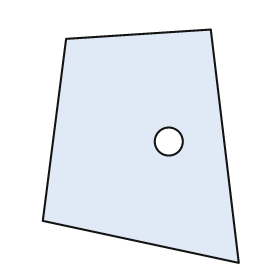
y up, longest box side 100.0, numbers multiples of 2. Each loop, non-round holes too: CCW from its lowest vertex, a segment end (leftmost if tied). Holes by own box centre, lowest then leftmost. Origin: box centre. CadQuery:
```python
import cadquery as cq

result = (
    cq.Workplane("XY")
    .moveTo(42.0, -50.0)
    .lineTo(30.0, 50.0)
    .lineTo(-32.0, 46.0)
    .lineTo(-42.0, -32.0)
    .close()
    .moveTo(12.0, 2.0)
    .circle(6.0)
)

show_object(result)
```